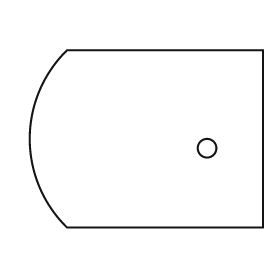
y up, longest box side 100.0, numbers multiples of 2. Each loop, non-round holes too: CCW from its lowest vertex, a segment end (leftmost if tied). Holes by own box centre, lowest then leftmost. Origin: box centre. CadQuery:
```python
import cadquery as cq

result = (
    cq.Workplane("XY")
    .moveTo(-34.0, -38.0)
    .lineTo(50.0, -38.0)
    .lineTo(50.0, 38.0)
    .lineTo(-34.0, 38.0)
    .threePointArc((-50.0, 0.0), (-34.0, -38.0))
    .close()
    .moveTo(26.0, -4.0)
    .circle(4.0)
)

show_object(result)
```